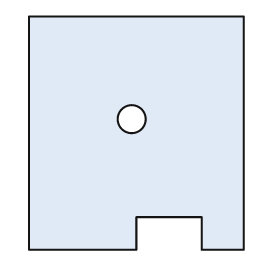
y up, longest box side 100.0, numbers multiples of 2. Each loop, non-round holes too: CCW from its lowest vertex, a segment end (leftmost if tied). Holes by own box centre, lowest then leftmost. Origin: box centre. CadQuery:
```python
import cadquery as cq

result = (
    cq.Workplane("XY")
    .moveTo(-46.0, -50.0)
    .lineTo(0.0, -50.0)
    .lineTo(0.0, -36.0)
    .lineTo(28.0, -36.0)
    .lineTo(28.0, -50.0)
    .lineTo(46.0, -50.0)
    .lineTo(46.0, 50.0)
    .lineTo(-46.0, 50.0)
    .close()
    .moveTo(-2.0, 6.0)
    .circle(6.0)
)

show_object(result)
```